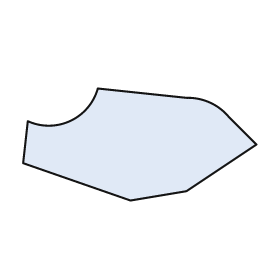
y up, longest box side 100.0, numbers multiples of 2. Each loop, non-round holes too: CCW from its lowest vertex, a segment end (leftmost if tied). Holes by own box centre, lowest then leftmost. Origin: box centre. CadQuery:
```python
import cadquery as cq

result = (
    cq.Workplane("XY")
    .moveTo(-4.0, -24.0)
    .lineTo(20.0, -20.0)
    .lineTo(50.0, 0.0)
    .lineTo(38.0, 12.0)
    .threePointArc((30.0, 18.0), (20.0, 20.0))
    .lineTo(-18.0, 24.0)
    .threePointArc((-30.0, 10.0), (-48.0, 10.0))
    .lineTo(-50.0, -8.0)
    .close()
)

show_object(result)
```